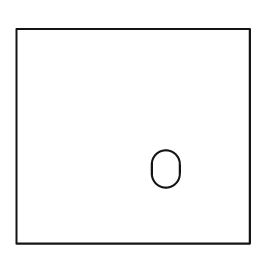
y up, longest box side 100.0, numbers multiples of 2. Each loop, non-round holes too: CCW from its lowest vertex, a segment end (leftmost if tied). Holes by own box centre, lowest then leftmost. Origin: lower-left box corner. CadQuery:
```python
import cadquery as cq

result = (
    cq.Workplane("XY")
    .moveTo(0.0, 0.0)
    .lineTo(100.0, 0.0)
    .lineTo(100.0, 92.0)
    .lineTo(0.0, 92.0)
    .close()
    .moveTo(58.0, 30.0)
    .threePointArc((64.0, 24.0), (70.0, 30.0))
    .lineTo(70.0, 34.0)
    .threePointArc((64.0, 40.0), (58.0, 34.0))
    .close()
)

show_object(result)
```